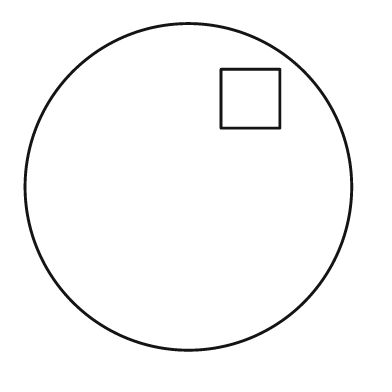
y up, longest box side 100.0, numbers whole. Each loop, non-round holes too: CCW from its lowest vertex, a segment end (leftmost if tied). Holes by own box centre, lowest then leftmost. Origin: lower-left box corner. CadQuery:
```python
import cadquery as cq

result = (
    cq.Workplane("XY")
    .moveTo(50.0, 50.0)
    .circle(50.0)
    .moveTo(60.0, 68.0)
    .lineTo(78.0, 68.0)
    .lineTo(78.0, 86.0)
    .lineTo(60.0, 86.0)
    .close()
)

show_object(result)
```